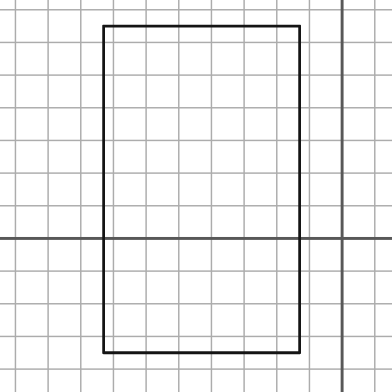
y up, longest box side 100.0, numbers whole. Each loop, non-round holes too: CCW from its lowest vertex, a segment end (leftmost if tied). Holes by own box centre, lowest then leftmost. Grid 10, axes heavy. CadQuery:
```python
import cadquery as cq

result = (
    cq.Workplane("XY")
    .moveTo(-73.0, -35.0)
    .lineTo(-13.0, -35.0)
    .lineTo(-13.0, 65.0)
    .lineTo(-73.0, 65.0)
    .close()
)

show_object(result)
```